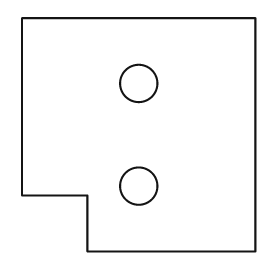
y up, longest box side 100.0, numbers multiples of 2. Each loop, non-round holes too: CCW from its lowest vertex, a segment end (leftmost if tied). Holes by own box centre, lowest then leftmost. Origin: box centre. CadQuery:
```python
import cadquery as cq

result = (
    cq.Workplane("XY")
    .moveTo(-22.0, -50.0)
    .lineTo(50.0, -50.0)
    .lineTo(50.0, 50.0)
    .lineTo(-50.0, 50.0)
    .lineTo(-50.0, -26.0)
    .lineTo(-22.0, -26.0)
    .close()
    .moveTo(0.0, -22.0)
    .circle(8.0)
    .moveTo(0.0, 22.0)
    .circle(8.0)
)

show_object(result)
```